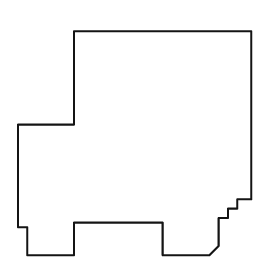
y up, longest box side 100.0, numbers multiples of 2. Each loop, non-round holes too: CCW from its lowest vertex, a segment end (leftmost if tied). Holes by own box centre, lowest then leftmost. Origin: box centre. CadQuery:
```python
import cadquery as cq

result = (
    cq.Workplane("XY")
    .moveTo(-46.0, -48.0)
    .lineTo(-26.0, -48.0)
    .lineTo(-26.0, -34.0)
    .lineTo(12.0, -34.0)
    .lineTo(12.0, -48.0)
    .lineTo(32.0, -48.0)
    .lineTo(36.0, -44.0)
    .lineTo(36.0, -32.0)
    .lineTo(40.0, -32.0)
    .lineTo(40.0, -28.0)
    .lineTo(44.0, -28.0)
    .lineTo(44.0, -24.0)
    .lineTo(50.0, -24.0)
    .lineTo(50.0, 48.0)
    .lineTo(-26.0, 48.0)
    .lineTo(-26.0, 8.0)
    .lineTo(-50.0, 8.0)
    .lineTo(-50.0, -36.0)
    .lineTo(-46.0, -36.0)
    .close()
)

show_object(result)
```